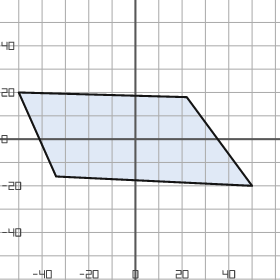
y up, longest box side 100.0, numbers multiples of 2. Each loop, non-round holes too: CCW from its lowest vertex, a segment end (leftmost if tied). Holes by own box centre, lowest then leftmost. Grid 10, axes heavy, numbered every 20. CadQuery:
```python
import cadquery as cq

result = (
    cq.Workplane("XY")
    .moveTo(50.0, -20.0)
    .lineTo(22.0, 18.0)
    .lineTo(-50.0, 20.0)
    .lineTo(-34.0, -16.0)
    .close()
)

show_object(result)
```